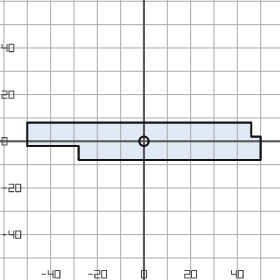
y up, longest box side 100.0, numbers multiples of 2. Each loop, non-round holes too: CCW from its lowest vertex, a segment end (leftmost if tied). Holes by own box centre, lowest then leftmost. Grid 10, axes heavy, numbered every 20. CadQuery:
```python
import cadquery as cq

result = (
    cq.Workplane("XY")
    .moveTo(-28.0, -8.0)
    .lineTo(50.0, -8.0)
    .lineTo(50.0, 2.0)
    .lineTo(46.0, 2.0)
    .lineTo(46.0, 8.0)
    .lineTo(-50.0, 8.0)
    .lineTo(-50.0, -2.0)
    .lineTo(-28.0, -2.0)
    .close()
    .moveTo(0.0, 0.0)
    .circle(2.0)
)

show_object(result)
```